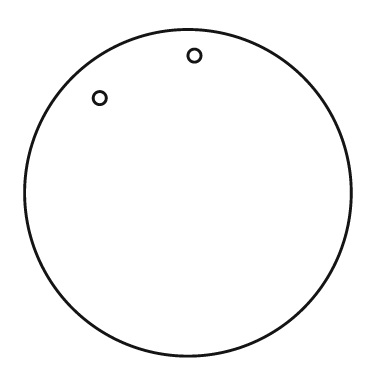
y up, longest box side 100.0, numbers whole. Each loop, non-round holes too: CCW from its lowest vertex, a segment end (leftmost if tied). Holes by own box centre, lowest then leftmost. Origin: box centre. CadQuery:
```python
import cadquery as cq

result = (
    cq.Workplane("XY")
    .moveTo(0.0, 0.0)
    .circle(50.0)
    .moveTo(-27.0, 29.0)
    .circle(2.0)
    .moveTo(2.0, 42.0)
    .circle(2.0)
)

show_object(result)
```